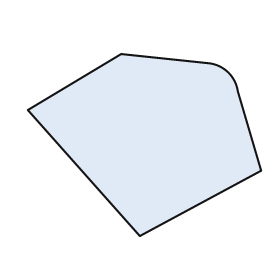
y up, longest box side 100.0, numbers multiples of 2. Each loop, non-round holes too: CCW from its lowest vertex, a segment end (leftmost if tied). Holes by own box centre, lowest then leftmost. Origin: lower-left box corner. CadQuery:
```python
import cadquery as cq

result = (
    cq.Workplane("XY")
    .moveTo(48.0, 0.0)
    .lineTo(100.0, 28.0)
    .lineTo(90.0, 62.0)
    .threePointArc((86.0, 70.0), (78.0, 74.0))
    .lineTo(40.0, 78.0)
    .lineTo(0.0, 54.0)
    .close()
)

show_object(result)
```